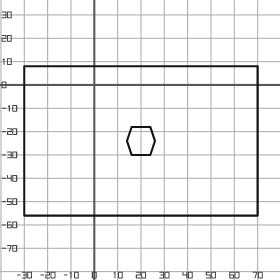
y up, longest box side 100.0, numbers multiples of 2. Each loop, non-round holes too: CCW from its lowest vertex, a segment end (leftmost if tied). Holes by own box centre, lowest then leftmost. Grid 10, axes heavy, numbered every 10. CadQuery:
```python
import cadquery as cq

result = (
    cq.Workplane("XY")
    .moveTo(-30.0, -56.0)
    .lineTo(70.0, -56.0)
    .lineTo(70.0, 8.0)
    .lineTo(-30.0, 8.0)
    .close()
    .moveTo(16.0, -30.0)
    .lineTo(24.0, -30.0)
    .lineTo(26.0, -24.0)
    .lineTo(24.0, -18.0)
    .lineTo(16.0, -18.0)
    .lineTo(14.0, -24.0)
    .close()
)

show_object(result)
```